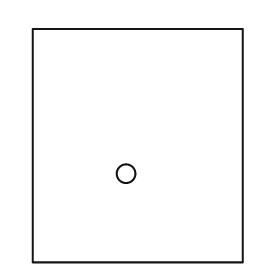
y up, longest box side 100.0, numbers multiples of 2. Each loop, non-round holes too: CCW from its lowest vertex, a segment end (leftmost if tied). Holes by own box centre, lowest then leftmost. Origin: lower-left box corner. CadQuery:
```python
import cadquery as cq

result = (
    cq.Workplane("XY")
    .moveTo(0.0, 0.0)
    .lineTo(90.0, 0.0)
    .lineTo(90.0, 100.0)
    .lineTo(0.0, 100.0)
    .close()
    .moveTo(40.0, 38.0)
    .circle(4.0)
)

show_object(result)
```